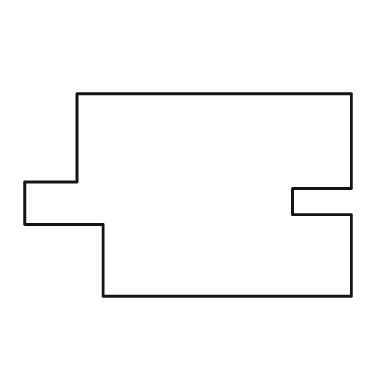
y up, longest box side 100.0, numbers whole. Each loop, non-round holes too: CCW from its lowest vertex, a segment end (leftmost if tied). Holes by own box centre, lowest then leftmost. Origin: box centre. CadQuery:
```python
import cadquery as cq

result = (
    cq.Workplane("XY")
    .moveTo(-26.0, -31.0)
    .lineTo(50.0, -31.0)
    .lineTo(50.0, -6.0)
    .lineTo(32.0, -6.0)
    .lineTo(32.0, 2.0)
    .lineTo(50.0, 2.0)
    .lineTo(50.0, 31.0)
    .lineTo(-34.0, 31.0)
    .lineTo(-34.0, 4.0)
    .lineTo(-50.0, 4.0)
    .lineTo(-50.0, -9.0)
    .lineTo(-26.0, -9.0)
    .close()
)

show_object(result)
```